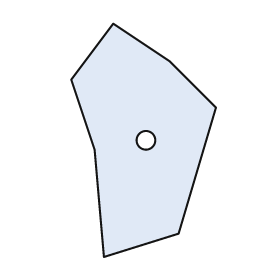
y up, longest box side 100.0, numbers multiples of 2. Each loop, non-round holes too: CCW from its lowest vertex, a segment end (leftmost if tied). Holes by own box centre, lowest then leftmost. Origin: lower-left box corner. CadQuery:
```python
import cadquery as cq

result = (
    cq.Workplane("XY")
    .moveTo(14.0, 0.0)
    .lineTo(46.0, 10.0)
    .lineTo(62.0, 64.0)
    .lineTo(42.0, 84.0)
    .lineTo(18.0, 100.0)
    .lineTo(0.0, 76.0)
    .lineTo(10.0, 46.0)
    .close()
    .moveTo(32.0, 50.0)
    .circle(4.0)
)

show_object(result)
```